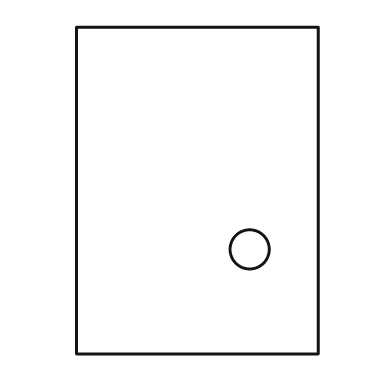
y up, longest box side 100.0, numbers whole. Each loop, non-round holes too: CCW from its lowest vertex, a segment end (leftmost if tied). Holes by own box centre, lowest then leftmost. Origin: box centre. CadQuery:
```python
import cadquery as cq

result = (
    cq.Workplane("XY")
    .moveTo(-37.0, -50.0)
    .lineTo(37.0, -50.0)
    .lineTo(37.0, 50.0)
    .lineTo(-37.0, 50.0)
    .close()
    .moveTo(16.0, -18.0)
    .circle(6.0)
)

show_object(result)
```